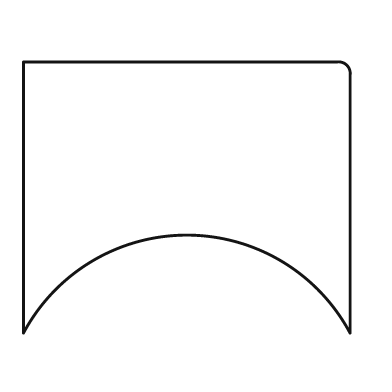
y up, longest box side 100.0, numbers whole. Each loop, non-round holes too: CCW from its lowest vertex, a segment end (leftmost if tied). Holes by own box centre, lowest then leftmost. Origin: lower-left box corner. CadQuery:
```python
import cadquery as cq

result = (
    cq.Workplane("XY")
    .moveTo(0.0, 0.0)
    .threePointArc((50.0, 30.0), (100.0, 0.0))
    .lineTo(100.0, 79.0)
    .threePointArc((99.0, 82.0), (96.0, 83.0))
    .lineTo(0.0, 83.0)
    .close()
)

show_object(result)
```